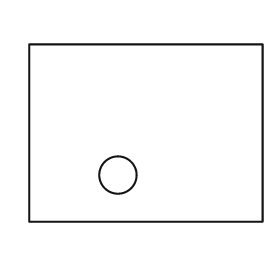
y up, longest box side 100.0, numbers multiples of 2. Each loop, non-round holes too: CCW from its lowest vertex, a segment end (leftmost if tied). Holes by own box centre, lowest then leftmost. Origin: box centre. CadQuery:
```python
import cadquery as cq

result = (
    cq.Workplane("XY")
    .moveTo(-50.0, -38.0)
    .lineTo(50.0, -38.0)
    .lineTo(50.0, 38.0)
    .lineTo(-50.0, 38.0)
    .close()
    .moveTo(-12.0, -18.0)
    .circle(8.0)
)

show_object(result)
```